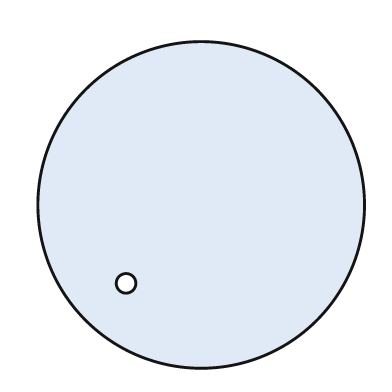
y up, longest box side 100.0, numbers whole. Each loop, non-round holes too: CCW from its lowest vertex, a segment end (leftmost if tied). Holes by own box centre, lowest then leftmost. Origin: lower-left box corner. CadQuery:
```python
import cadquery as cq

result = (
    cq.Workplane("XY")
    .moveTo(50.0, 50.0)
    .circle(50.0)
    .moveTo(27.0, 26.0)
    .circle(3.0)
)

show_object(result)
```